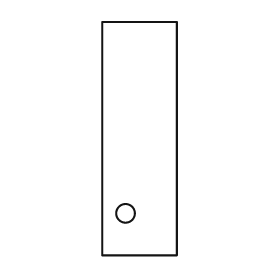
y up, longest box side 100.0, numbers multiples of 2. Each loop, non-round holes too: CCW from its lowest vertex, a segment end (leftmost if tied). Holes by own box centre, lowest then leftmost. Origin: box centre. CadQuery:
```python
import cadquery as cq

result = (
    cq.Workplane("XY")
    .moveTo(-16.0, -50.0)
    .lineTo(16.0, -50.0)
    .lineTo(16.0, 50.0)
    .lineTo(-16.0, 50.0)
    .close()
    .moveTo(-6.0, -32.0)
    .circle(4.0)
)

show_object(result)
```